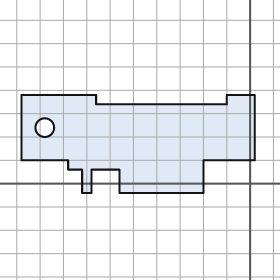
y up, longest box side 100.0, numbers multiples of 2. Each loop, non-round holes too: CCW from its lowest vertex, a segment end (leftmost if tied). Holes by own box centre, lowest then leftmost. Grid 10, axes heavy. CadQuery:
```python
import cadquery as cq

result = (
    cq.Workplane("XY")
    .moveTo(-72.0, -4.0)
    .lineTo(-68.0, -4.0)
    .lineTo(-68.0, 6.0)
    .lineTo(-56.0, 6.0)
    .lineTo(-56.0, -4.0)
    .lineTo(-20.0, -4.0)
    .lineTo(-20.0, 10.0)
    .lineTo(2.0, 10.0)
    .lineTo(2.0, 38.0)
    .lineTo(-10.0, 38.0)
    .lineTo(-10.0, 34.0)
    .lineTo(-66.0, 34.0)
    .lineTo(-66.0, 38.0)
    .lineTo(-98.0, 38.0)
    .lineTo(-98.0, 10.0)
    .lineTo(-78.0, 10.0)
    .lineTo(-78.0, 6.0)
    .lineTo(-72.0, 6.0)
    .close()
    .moveTo(-88.0, 24.0)
    .circle(4.0)
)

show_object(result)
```